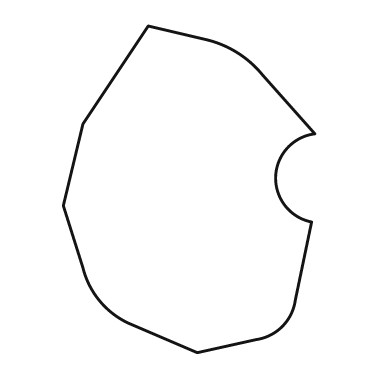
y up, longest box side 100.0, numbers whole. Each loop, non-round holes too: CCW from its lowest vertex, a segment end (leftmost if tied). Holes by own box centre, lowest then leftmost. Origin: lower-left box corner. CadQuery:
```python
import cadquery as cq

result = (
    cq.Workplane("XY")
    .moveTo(41.0, 0.0)
    .lineTo(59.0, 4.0)
    .threePointArc((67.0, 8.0), (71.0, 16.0))
    .lineTo(76.0, 40.0)
    .threePointArc((65.0, 54.0), (77.0, 67.0))
    .lineTo(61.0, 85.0)
    .threePointArc((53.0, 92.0), (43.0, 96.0))
    .lineTo(26.0, 100.0)
    .lineTo(6.0, 70.0)
    .lineTo(0.0, 45.0)
    .lineTo(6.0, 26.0)
    .threePointArc((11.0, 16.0), (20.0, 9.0))
    .close()
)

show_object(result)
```